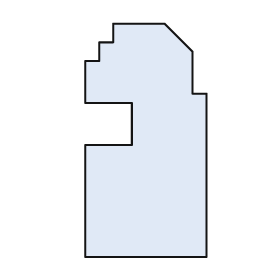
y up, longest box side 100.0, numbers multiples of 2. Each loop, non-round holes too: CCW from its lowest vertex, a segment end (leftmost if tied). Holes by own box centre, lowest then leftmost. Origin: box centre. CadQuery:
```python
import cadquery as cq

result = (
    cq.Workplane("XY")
    .moveTo(-26.0, -50.0)
    .lineTo(26.0, -50.0)
    .lineTo(26.0, 20.0)
    .lineTo(20.0, 20.0)
    .lineTo(20.0, 38.0)
    .lineTo(8.0, 50.0)
    .lineTo(-14.0, 50.0)
    .lineTo(-14.0, 42.0)
    .lineTo(-20.0, 42.0)
    .lineTo(-20.0, 34.0)
    .lineTo(-26.0, 34.0)
    .lineTo(-26.0, 16.0)
    .lineTo(-6.0, 16.0)
    .lineTo(-6.0, -2.0)
    .lineTo(-26.0, -2.0)
    .close()
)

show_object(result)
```